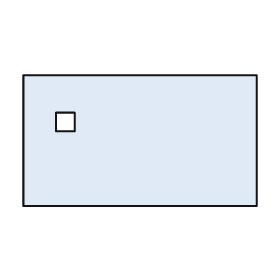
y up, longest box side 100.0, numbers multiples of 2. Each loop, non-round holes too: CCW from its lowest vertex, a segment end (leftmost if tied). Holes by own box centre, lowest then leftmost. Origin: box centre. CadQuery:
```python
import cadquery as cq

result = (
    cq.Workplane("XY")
    .moveTo(-50.0, -28.0)
    .lineTo(50.0, -28.0)
    .lineTo(50.0, 28.0)
    .lineTo(-50.0, 28.0)
    .close()
    .moveTo(-36.0, 4.0)
    .lineTo(-28.0, 4.0)
    .lineTo(-28.0, 12.0)
    .lineTo(-36.0, 12.0)
    .close()
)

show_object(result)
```